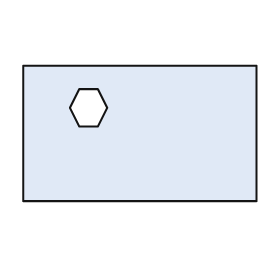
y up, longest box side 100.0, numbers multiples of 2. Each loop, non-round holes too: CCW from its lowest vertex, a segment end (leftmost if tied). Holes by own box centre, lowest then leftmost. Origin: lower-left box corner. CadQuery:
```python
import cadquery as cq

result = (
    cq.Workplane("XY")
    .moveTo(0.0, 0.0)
    .lineTo(100.0, 0.0)
    .lineTo(100.0, 58.0)
    .lineTo(0.0, 58.0)
    .close()
    .moveTo(24.0, 32.0)
    .lineTo(32.0, 32.0)
    .lineTo(36.0, 40.0)
    .lineTo(32.0, 48.0)
    .lineTo(24.0, 48.0)
    .lineTo(20.0, 40.0)
    .close()
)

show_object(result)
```